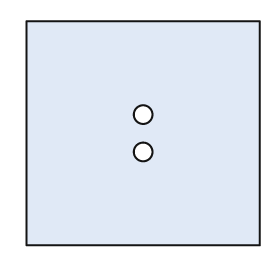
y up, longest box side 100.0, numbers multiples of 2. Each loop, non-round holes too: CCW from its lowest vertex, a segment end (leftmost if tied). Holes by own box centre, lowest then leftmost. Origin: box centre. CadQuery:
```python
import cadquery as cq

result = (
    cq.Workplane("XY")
    .moveTo(-50.0, -48.0)
    .lineTo(50.0, -48.0)
    .lineTo(50.0, 48.0)
    .lineTo(-50.0, 48.0)
    .close()
    .moveTo(0.0, -8.0)
    .circle(4.0)
    .moveTo(0.0, 8.0)
    .circle(4.0)
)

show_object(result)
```